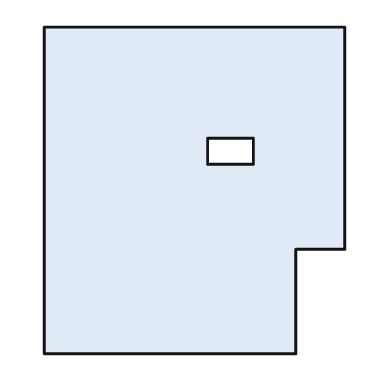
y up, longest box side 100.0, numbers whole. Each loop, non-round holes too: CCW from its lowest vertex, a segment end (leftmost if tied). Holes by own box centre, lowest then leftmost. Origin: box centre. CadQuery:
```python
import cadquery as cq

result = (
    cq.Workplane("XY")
    .moveTo(-46.0, -50.0)
    .lineTo(31.0, -50.0)
    .lineTo(31.0, -18.0)
    .lineTo(46.0, -18.0)
    .lineTo(46.0, 50.0)
    .lineTo(-46.0, 50.0)
    .close()
    .moveTo(4.0, 8.0)
    .lineTo(18.0, 8.0)
    .lineTo(18.0, 16.0)
    .lineTo(4.0, 16.0)
    .close()
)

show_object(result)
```